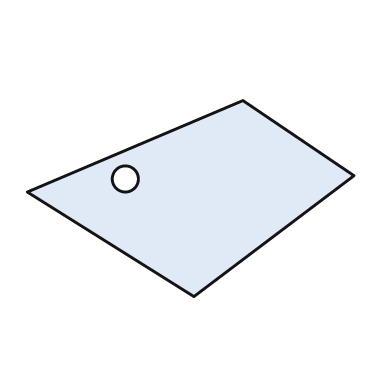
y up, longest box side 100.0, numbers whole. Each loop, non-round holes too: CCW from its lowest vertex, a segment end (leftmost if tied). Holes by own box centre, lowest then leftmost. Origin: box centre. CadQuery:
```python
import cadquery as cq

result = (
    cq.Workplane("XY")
    .moveTo(1.0, -30.0)
    .lineTo(50.0, 7.0)
    .lineTo(16.0, 30.0)
    .lineTo(-50.0, 2.0)
    .close()
    .moveTo(-20.0, 6.0)
    .circle(4.0)
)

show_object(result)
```